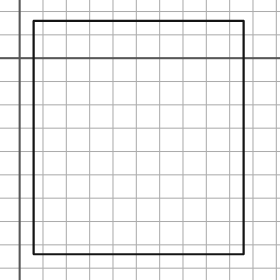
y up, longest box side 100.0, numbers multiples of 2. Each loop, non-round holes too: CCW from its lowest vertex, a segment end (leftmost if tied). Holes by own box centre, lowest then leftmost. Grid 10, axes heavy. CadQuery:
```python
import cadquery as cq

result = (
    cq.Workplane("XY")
    .moveTo(6.0, -84.0)
    .lineTo(96.0, -84.0)
    .lineTo(96.0, 16.0)
    .lineTo(6.0, 16.0)
    .close()
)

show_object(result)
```